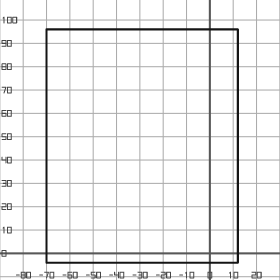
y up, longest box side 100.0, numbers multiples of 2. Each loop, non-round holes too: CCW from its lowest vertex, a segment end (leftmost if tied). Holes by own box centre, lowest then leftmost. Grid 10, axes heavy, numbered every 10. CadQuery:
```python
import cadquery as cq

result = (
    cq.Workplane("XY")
    .moveTo(-70.0, -4.0)
    .lineTo(12.0, -4.0)
    .lineTo(12.0, 96.0)
    .lineTo(-70.0, 96.0)
    .close()
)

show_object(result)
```